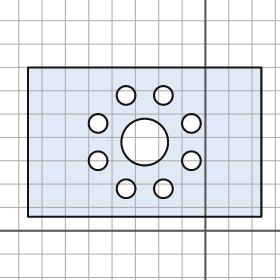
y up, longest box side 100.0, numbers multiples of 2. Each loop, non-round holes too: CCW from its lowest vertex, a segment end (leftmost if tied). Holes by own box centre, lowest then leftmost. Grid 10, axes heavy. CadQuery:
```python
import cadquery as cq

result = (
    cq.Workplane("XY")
    .moveTo(-76.0, 6.0)
    .lineTo(24.0, 6.0)
    .lineTo(24.0, 70.0)
    .lineTo(-76.0, 70.0)
    .close()
    .moveTo(-34.0, 18.0)
    .circle(4.0)
    .moveTo(-18.0, 18.0)
    .circle(4.0)
    .moveTo(-46.0, 30.0)
    .circle(4.0)
    .moveTo(-6.0, 30.0)
    .circle(4.0)
    .moveTo(-26.0, 38.0)
    .circle(10.0)
    .moveTo(-46.0, 46.0)
    .circle(4.0)
    .moveTo(-6.0, 46.0)
    .circle(4.0)
    .moveTo(-34.0, 58.0)
    .circle(4.0)
    .moveTo(-18.0, 58.0)
    .circle(4.0)
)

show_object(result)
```